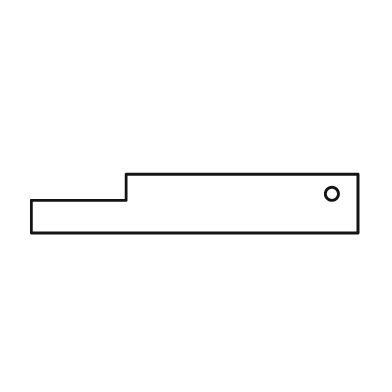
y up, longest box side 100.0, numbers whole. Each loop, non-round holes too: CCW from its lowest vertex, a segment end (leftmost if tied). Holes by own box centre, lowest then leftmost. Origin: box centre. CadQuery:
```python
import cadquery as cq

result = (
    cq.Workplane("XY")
    .moveTo(-50.0, -9.0)
    .lineTo(50.0, -9.0)
    .lineTo(50.0, 9.0)
    .lineTo(-21.0, 9.0)
    .lineTo(-21.0, 1.0)
    .lineTo(-50.0, 1.0)
    .close()
    .moveTo(42.0, 3.0)
    .circle(2.0)
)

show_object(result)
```